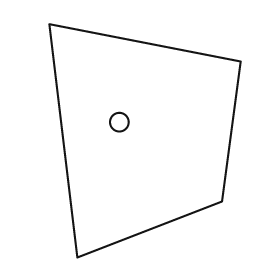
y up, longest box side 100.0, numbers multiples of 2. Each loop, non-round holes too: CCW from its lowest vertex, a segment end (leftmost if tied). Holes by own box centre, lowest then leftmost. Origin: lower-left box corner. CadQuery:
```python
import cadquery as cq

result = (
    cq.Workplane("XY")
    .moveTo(12.0, 0.0)
    .lineTo(74.0, 24.0)
    .lineTo(82.0, 84.0)
    .lineTo(0.0, 100.0)
    .close()
    .moveTo(30.0, 58.0)
    .circle(4.0)
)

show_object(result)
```